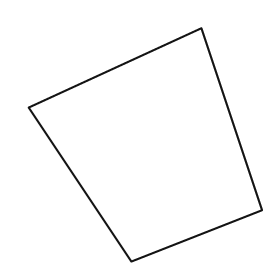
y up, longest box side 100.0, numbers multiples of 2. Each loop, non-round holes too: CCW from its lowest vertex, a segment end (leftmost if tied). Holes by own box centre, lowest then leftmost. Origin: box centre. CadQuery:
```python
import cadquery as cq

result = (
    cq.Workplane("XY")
    .moveTo(-6.0, -50.0)
    .lineTo(50.0, -28.0)
    .lineTo(24.0, 50.0)
    .lineTo(-50.0, 16.0)
    .close()
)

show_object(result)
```